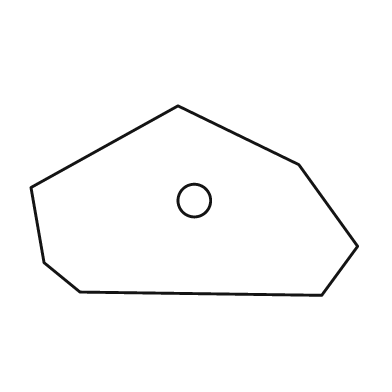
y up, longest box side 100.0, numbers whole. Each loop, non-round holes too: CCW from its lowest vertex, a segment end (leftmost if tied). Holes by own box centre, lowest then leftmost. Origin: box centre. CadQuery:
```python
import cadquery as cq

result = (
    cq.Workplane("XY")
    .moveTo(39.0, -29.0)
    .lineTo(50.0, -14.0)
    .lineTo(32.0, 11.0)
    .lineTo(-5.0, 29.0)
    .lineTo(-50.0, 4.0)
    .lineTo(-46.0, -19.0)
    .lineTo(-35.0, -28.0)
    .close()
    .moveTo(0.0, 0.0)
    .circle(5.0)
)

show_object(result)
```